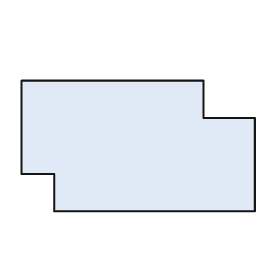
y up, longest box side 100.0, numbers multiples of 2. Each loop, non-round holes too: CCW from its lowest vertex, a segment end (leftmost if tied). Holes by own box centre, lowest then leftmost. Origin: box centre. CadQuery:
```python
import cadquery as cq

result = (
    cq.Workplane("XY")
    .moveTo(-36.0, -28.0)
    .lineTo(50.0, -28.0)
    .lineTo(50.0, 12.0)
    .lineTo(28.0, 12.0)
    .lineTo(28.0, 28.0)
    .lineTo(-50.0, 28.0)
    .lineTo(-50.0, -12.0)
    .lineTo(-36.0, -12.0)
    .close()
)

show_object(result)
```